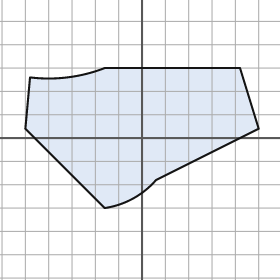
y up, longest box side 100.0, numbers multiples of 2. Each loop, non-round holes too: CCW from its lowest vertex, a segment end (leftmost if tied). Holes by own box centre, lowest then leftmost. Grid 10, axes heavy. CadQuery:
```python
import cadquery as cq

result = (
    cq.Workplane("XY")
    .moveTo(-16.0, -30.0)
    .threePointArc((-4.0, -26.0), (6.0, -18.0))
    .lineTo(50.0, 4.0)
    .lineTo(42.0, 30.0)
    .lineTo(-16.0, 30.0)
    .threePointArc((-32.0, 26.0), (-48.0, 26.0))
    .lineTo(-50.0, 4.0)
    .close()
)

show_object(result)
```